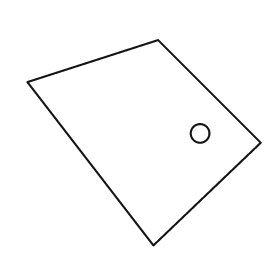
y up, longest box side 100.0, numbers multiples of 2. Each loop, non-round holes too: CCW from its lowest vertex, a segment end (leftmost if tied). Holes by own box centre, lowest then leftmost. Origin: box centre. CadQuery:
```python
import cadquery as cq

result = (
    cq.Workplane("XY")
    .moveTo(4.0, -44.0)
    .lineTo(50.0, 0.0)
    .lineTo(6.0, 44.0)
    .lineTo(-50.0, 26.0)
    .close()
    .moveTo(24.0, 4.0)
    .circle(4.0)
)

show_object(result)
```